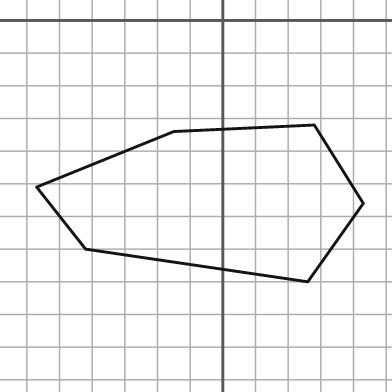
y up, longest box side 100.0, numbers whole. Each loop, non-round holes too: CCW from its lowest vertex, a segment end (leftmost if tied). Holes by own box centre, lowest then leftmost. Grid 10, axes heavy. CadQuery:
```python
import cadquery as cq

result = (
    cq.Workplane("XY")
    .moveTo(26.0, -80.0)
    .lineTo(43.0, -56.0)
    .lineTo(28.0, -32.0)
    .lineTo(-15.0, -34.0)
    .lineTo(-57.0, -51.0)
    .lineTo(-42.0, -70.0)
    .close()
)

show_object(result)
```